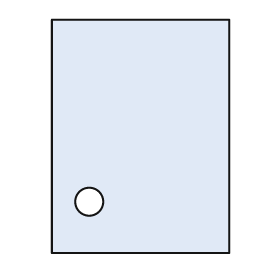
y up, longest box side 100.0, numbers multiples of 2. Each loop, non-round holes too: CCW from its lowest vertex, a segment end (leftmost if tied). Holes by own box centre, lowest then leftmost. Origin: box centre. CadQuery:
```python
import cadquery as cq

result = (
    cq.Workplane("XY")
    .moveTo(-38.0, -50.0)
    .lineTo(38.0, -50.0)
    .lineTo(38.0, 50.0)
    .lineTo(-38.0, 50.0)
    .close()
    .moveTo(-22.0, -28.0)
    .circle(6.0)
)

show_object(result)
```